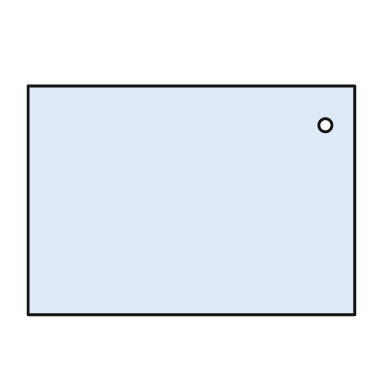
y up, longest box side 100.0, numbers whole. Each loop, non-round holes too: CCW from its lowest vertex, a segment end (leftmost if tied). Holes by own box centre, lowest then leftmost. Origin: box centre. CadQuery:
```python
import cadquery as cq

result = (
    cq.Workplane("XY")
    .moveTo(-50.0, -35.0)
    .lineTo(50.0, -35.0)
    .lineTo(50.0, 35.0)
    .lineTo(-50.0, 35.0)
    .close()
    .moveTo(41.0, 23.0)
    .circle(2.0)
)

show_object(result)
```